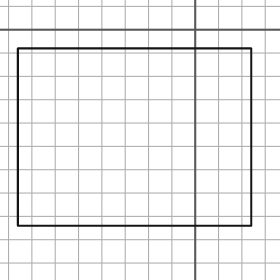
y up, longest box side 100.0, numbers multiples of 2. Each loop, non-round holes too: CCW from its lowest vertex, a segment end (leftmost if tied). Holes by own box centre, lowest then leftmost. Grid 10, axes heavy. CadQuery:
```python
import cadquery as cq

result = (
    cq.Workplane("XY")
    .moveTo(-76.0, -84.0)
    .lineTo(24.0, -84.0)
    .lineTo(24.0, -8.0)
    .lineTo(-76.0, -8.0)
    .close()
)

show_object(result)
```